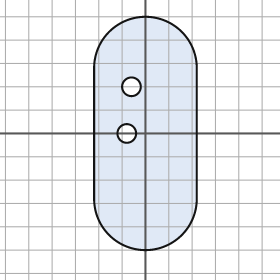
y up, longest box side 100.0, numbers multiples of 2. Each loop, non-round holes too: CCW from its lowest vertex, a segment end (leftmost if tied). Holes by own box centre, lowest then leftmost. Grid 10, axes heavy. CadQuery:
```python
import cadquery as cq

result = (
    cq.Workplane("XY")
    .moveTo(-22.0, -28.0)
    .threePointArc((0.0, -50.0), (22.0, -28.0))
    .lineTo(22.0, 28.0)
    .threePointArc((0.0, 50.0), (-22.0, 28.0))
    .close()
    .moveTo(-8.0, 0.0)
    .circle(4.0)
    .moveTo(-6.0, 20.0)
    .circle(4.0)
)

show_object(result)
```